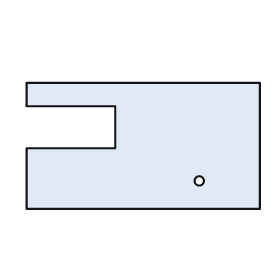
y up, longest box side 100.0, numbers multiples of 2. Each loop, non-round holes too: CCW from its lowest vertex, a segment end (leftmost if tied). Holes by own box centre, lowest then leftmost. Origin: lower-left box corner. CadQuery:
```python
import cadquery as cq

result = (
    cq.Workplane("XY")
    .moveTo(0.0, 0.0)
    .lineTo(100.0, 0.0)
    .lineTo(100.0, 54.0)
    .lineTo(0.0, 54.0)
    .lineTo(0.0, 44.0)
    .lineTo(38.0, 44.0)
    .lineTo(38.0, 26.0)
    .lineTo(0.0, 26.0)
    .close()
    .moveTo(74.0, 12.0)
    .circle(2.0)
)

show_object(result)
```